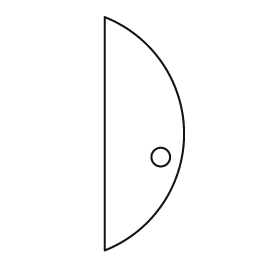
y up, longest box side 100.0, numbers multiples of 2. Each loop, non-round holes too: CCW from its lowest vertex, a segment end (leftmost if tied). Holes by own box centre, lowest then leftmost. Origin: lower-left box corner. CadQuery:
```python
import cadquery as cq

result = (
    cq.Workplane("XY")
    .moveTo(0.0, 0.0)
    .threePointArc((34.0, 50.0), (0.0, 100.0))
    .close()
    .moveTo(24.0, 40.0)
    .circle(4.0)
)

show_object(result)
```